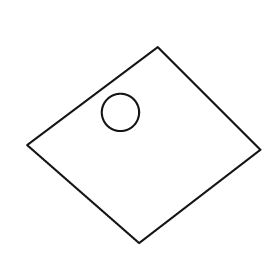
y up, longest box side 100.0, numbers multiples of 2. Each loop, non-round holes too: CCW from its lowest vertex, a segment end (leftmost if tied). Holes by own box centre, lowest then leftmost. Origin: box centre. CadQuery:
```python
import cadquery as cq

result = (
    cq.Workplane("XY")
    .moveTo(-2.0, -42.0)
    .lineTo(50.0, -2.0)
    .lineTo(6.0, 42.0)
    .lineTo(-50.0, 0.0)
    .close()
    .moveTo(-10.0, 14.0)
    .circle(8.0)
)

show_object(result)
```